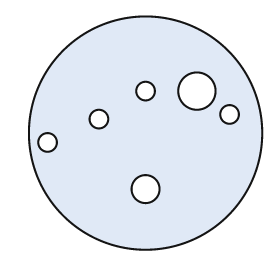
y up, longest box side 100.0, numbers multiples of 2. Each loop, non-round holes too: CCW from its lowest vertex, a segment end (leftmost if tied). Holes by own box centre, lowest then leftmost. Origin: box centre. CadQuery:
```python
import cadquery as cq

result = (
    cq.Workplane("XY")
    .moveTo(0.0, 0.0)
    .circle(50.0)
    .moveTo(0.0, -24.0)
    .circle(6.0)
    .moveTo(-42.0, -4.0)
    .circle(4.0)
    .moveTo(-20.0, 6.0)
    .circle(4.0)
    .moveTo(36.0, 8.0)
    .circle(4.0)
    .moveTo(0.0, 18.0)
    .circle(4.0)
    .moveTo(22.0, 18.0)
    .circle(8.0)
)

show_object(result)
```